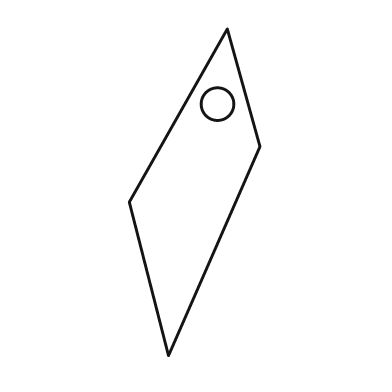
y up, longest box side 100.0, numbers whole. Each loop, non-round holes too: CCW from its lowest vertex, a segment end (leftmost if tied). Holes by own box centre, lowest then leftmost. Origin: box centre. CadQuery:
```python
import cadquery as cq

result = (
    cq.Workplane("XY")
    .moveTo(-8.0, -50.0)
    .lineTo(20.0, 14.0)
    .lineTo(10.0, 50.0)
    .lineTo(-20.0, -3.0)
    .close()
    .moveTo(7.0, 27.0)
    .circle(5.0)
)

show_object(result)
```